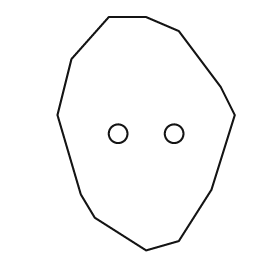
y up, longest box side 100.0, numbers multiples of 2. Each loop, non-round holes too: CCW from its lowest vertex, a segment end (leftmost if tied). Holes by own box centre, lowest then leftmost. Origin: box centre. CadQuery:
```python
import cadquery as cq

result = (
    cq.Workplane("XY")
    .moveTo(0.0, -50.0)
    .lineTo(14.0, -46.0)
    .lineTo(28.0, -24.0)
    .lineTo(38.0, 8.0)
    .lineTo(32.0, 20.0)
    .lineTo(14.0, 44.0)
    .lineTo(0.0, 50.0)
    .lineTo(-16.0, 50.0)
    .lineTo(-32.0, 32.0)
    .lineTo(-38.0, 8.0)
    .lineTo(-28.0, -26.0)
    .lineTo(-22.0, -36.0)
    .close()
    .moveTo(-12.0, 0.0)
    .circle(4.0)
    .moveTo(12.0, 0.0)
    .circle(4.0)
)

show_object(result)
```